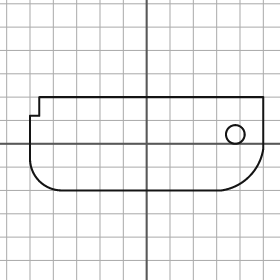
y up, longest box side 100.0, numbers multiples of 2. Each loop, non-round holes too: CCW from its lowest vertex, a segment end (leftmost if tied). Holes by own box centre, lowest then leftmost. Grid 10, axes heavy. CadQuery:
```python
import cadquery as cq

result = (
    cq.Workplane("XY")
    .moveTo(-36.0, -20.0)
    .lineTo(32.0, -20.0)
    .threePointArc((44.0, -14.0), (50.0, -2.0))
    .lineTo(50.0, 20.0)
    .lineTo(-46.0, 20.0)
    .lineTo(-46.0, 12.0)
    .lineTo(-50.0, 12.0)
    .lineTo(-50.0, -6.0)
    .threePointArc((-46.0, -16.0), (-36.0, -20.0))
    .close()
    .moveTo(38.0, 4.0)
    .circle(4.0)
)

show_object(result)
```